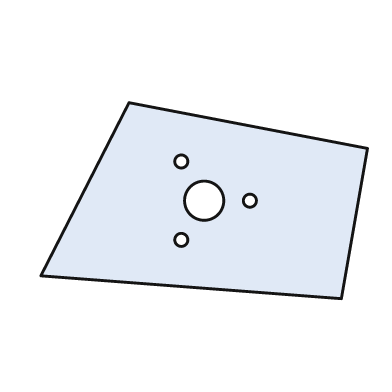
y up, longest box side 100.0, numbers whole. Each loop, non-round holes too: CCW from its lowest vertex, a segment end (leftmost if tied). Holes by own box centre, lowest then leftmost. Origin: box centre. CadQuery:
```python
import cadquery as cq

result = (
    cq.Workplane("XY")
    .moveTo(42.0, -30.0)
    .lineTo(50.0, 16.0)
    .lineTo(-23.0, 30.0)
    .lineTo(-50.0, -23.0)
    .close()
    .moveTo(-7.0, -12.0)
    .circle(2.0)
    .moveTo(0.0, 0.0)
    .circle(6.0)
    .moveTo(14.0, 0.0)
    .circle(2.0)
    .moveTo(-7.0, 12.0)
    .circle(2.0)
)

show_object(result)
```